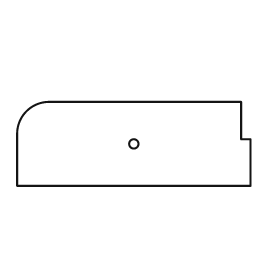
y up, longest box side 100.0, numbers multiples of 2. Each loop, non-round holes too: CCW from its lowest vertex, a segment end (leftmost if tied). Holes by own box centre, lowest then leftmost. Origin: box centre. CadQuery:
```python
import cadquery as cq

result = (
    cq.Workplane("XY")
    .moveTo(-50.0, -18.0)
    .lineTo(50.0, -18.0)
    .lineTo(50.0, 2.0)
    .lineTo(46.0, 2.0)
    .lineTo(46.0, 18.0)
    .lineTo(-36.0, 18.0)
    .threePointArc((-46.0, 14.0), (-50.0, 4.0))
    .close()
    .moveTo(0.0, 0.0)
    .circle(2.0)
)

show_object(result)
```